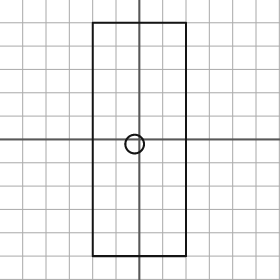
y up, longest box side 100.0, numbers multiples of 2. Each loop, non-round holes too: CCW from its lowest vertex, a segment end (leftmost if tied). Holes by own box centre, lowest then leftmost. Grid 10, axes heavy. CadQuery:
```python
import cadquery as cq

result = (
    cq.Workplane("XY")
    .moveTo(-20.0, -50.0)
    .lineTo(20.0, -50.0)
    .lineTo(20.0, 50.0)
    .lineTo(-20.0, 50.0)
    .close()
    .moveTo(-2.0, -2.0)
    .circle(4.0)
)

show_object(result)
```